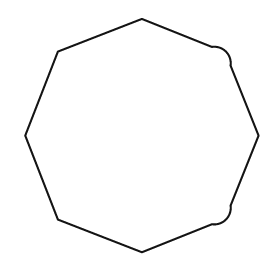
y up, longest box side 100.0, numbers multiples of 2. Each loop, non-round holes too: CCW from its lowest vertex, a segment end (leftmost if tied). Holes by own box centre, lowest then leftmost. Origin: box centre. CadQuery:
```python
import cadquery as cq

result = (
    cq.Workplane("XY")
    .moveTo(0.0, -50.0)
    .lineTo(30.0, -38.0)
    .threePointArc((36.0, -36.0), (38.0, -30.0))
    .lineTo(50.0, 0.0)
    .lineTo(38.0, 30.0)
    .threePointArc((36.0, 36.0), (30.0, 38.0))
    .lineTo(0.0, 50.0)
    .lineTo(-36.0, 36.0)
    .lineTo(-50.0, 0.0)
    .lineTo(-36.0, -36.0)
    .close()
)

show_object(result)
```